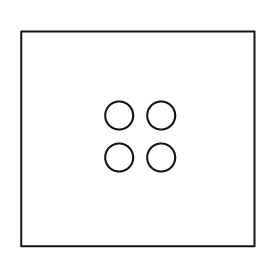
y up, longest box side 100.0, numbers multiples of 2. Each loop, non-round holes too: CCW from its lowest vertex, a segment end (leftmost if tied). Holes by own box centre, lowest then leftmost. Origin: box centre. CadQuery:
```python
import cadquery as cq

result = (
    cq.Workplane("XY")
    .moveTo(-50.0, -46.0)
    .lineTo(50.0, -46.0)
    .lineTo(50.0, 46.0)
    .lineTo(-50.0, 46.0)
    .close()
    .moveTo(-8.0, -8.0)
    .circle(6.0)
    .moveTo(10.0, -8.0)
    .circle(6.0)
    .moveTo(-8.0, 10.0)
    .circle(6.0)
    .moveTo(10.0, 10.0)
    .circle(6.0)
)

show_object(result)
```